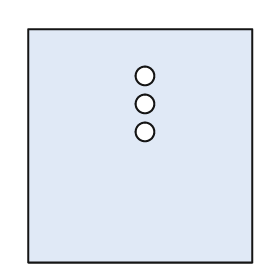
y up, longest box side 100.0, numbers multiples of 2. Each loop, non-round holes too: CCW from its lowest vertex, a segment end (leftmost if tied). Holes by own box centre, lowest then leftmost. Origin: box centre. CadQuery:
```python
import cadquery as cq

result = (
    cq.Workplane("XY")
    .moveTo(-48.0, -50.0)
    .lineTo(48.0, -50.0)
    .lineTo(48.0, 50.0)
    .lineTo(-48.0, 50.0)
    .close()
    .moveTo(2.0, 6.0)
    .circle(4.0)
    .moveTo(2.0, 18.0)
    .circle(4.0)
    .moveTo(2.0, 30.0)
    .circle(4.0)
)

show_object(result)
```